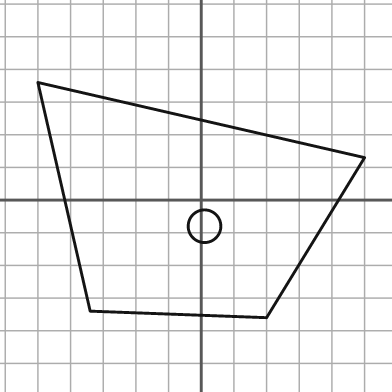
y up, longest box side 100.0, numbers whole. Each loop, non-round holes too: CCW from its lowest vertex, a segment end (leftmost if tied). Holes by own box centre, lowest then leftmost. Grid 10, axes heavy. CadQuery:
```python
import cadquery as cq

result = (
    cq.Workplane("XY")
    .moveTo(20.0, -36.0)
    .lineTo(50.0, 13.0)
    .lineTo(-50.0, 36.0)
    .lineTo(-34.0, -34.0)
    .close()
    .moveTo(1.0, -8.0)
    .circle(5.0)
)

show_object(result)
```